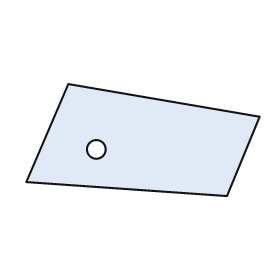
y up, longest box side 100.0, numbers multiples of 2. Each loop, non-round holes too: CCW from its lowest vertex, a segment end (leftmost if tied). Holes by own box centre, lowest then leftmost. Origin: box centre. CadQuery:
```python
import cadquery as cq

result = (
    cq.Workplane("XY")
    .moveTo(36.0, -24.0)
    .lineTo(50.0, 10.0)
    .lineTo(-32.0, 24.0)
    .lineTo(-50.0, -18.0)
    .close()
    .moveTo(-20.0, -4.0)
    .circle(4.0)
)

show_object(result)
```